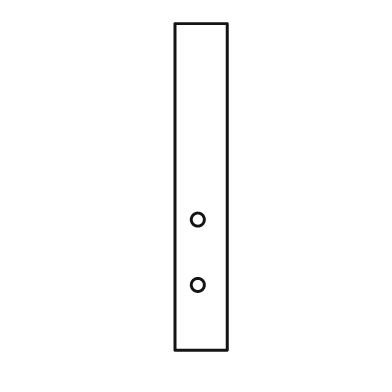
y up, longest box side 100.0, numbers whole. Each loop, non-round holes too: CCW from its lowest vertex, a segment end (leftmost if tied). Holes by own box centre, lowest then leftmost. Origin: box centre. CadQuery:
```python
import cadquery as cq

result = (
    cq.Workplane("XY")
    .moveTo(-8.0, -50.0)
    .lineTo(8.0, -50.0)
    .lineTo(8.0, 50.0)
    .lineTo(-8.0, 50.0)
    .close()
    .moveTo(-1.0, -30.0)
    .circle(2.0)
    .moveTo(-1.0, -10.0)
    .circle(2.0)
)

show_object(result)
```